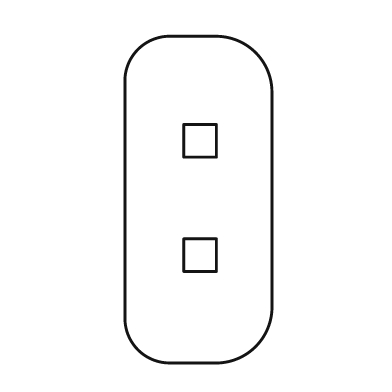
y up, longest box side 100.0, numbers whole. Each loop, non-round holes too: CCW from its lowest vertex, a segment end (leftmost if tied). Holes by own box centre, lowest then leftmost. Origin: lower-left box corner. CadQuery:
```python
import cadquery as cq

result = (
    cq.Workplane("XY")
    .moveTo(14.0, 0.0)
    .lineTo(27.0, 0.0)
    .threePointArc((40.0, 5.0), (45.0, 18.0))
    .lineTo(45.0, 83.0)
    .threePointArc((40.0, 95.0), (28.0, 100.0))
    .lineTo(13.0, 100.0)
    .threePointArc((4.0, 96.0), (0.0, 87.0))
    .lineTo(0.0, 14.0)
    .threePointArc((4.0, 4.0), (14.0, 0.0))
    .close()
    .moveTo(18.0, 28.0)
    .lineTo(28.0, 28.0)
    .lineTo(28.0, 38.0)
    .lineTo(18.0, 38.0)
    .close()
    .moveTo(18.0, 63.0)
    .lineTo(28.0, 63.0)
    .lineTo(28.0, 73.0)
    .lineTo(18.0, 73.0)
    .close()
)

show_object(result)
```